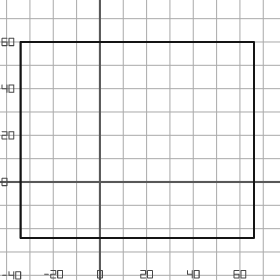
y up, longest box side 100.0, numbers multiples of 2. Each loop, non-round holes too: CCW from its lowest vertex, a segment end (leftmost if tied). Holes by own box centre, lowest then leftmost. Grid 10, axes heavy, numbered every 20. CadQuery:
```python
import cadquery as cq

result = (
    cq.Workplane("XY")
    .moveTo(-34.0, -24.0)
    .lineTo(66.0, -24.0)
    .lineTo(66.0, 60.0)
    .lineTo(-34.0, 60.0)
    .close()
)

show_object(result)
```